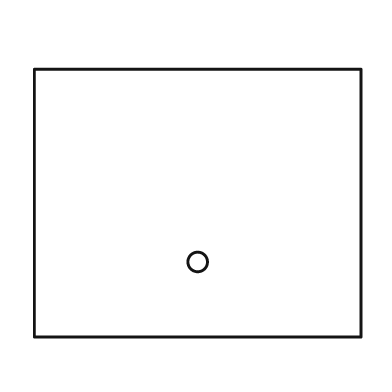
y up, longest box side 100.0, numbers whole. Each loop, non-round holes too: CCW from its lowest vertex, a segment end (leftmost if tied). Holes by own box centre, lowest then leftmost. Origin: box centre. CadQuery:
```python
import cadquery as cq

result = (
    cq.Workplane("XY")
    .moveTo(-50.0, -41.0)
    .lineTo(50.0, -41.0)
    .lineTo(50.0, 41.0)
    .lineTo(-50.0, 41.0)
    .close()
    .moveTo(0.0, -18.0)
    .circle(3.0)
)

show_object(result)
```